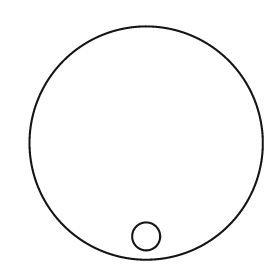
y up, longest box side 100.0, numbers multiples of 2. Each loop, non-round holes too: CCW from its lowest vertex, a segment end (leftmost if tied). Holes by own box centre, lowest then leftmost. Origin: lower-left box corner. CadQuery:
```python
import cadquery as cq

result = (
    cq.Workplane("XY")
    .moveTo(50.0, 50.0)
    .circle(50.0)
    .moveTo(50.0, 10.0)
    .circle(6.0)
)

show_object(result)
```